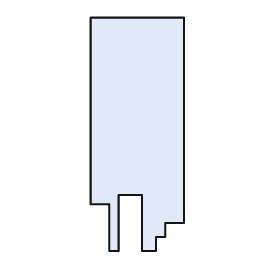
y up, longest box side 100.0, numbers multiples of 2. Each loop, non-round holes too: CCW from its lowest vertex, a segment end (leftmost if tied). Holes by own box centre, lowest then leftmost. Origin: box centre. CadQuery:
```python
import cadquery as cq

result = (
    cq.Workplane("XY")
    .moveTo(-12.0, -50.0)
    .lineTo(-8.0, -50.0)
    .lineTo(-8.0, -26.0)
    .lineTo(2.0, -26.0)
    .lineTo(2.0, -50.0)
    .lineTo(8.0, -50.0)
    .lineTo(8.0, -44.0)
    .lineTo(12.0, -44.0)
    .lineTo(12.0, -38.0)
    .lineTo(20.0, -38.0)
    .lineTo(20.0, 50.0)
    .lineTo(-20.0, 50.0)
    .lineTo(-20.0, -30.0)
    .lineTo(-12.0, -30.0)
    .close()
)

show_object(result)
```